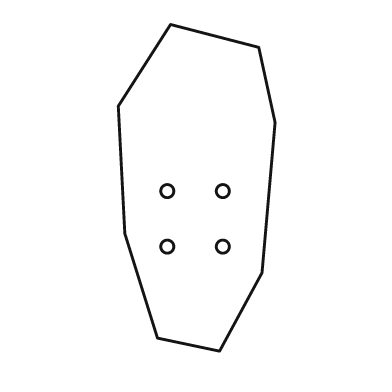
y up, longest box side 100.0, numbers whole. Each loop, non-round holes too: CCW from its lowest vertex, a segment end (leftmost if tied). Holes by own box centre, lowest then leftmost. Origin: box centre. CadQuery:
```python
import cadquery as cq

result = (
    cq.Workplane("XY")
    .moveTo(7.0, -50.0)
    .lineTo(20.0, -26.0)
    .lineTo(24.0, 20.0)
    .lineTo(19.0, 43.0)
    .lineTo(-8.0, 50.0)
    .lineTo(-24.0, 25.0)
    .lineTo(-22.0, -14.0)
    .lineTo(-12.0, -46.0)
    .close()
    .moveTo(-9.0, -18.0)
    .circle(2.0)
    .moveTo(8.0, -18.0)
    .circle(2.0)
    .moveTo(-9.0, -1.0)
    .circle(2.0)
    .moveTo(8.0, -1.0)
    .circle(2.0)
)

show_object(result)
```